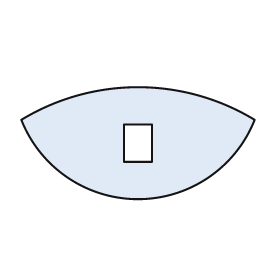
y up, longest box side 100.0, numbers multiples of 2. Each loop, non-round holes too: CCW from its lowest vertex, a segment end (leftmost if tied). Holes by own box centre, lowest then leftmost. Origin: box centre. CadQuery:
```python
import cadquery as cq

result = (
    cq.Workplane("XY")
    .moveTo(-50.0, 10.0)
    .threePointArc((0.0, -24.0), (50.0, 10.0))
    .threePointArc((0.0, 24.0), (-50.0, 10.0))
    .close()
    .moveTo(-6.0, -8.0)
    .lineTo(6.0, -8.0)
    .lineTo(6.0, 8.0)
    .lineTo(-6.0, 8.0)
    .close()
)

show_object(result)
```